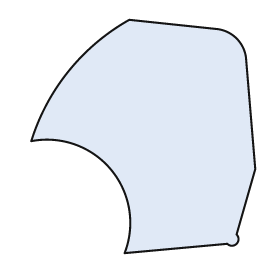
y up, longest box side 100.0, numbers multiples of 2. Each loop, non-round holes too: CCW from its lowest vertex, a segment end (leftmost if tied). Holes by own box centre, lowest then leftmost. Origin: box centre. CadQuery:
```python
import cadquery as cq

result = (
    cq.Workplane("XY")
    .moveTo(-8.0, -50.0)
    .lineTo(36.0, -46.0)
    .threePointArc((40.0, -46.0), (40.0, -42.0))
    .lineTo(48.0, -14.0)
    .lineTo(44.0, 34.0)
    .threePointArc((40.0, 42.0), (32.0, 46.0))
    .lineTo(-6.0, 50.0)
    .threePointArc((-32.0, 28.0), (-48.0, -2.0))
    .threePointArc((-14.0, -14.0), (-8.0, -50.0))
    .close()
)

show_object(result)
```